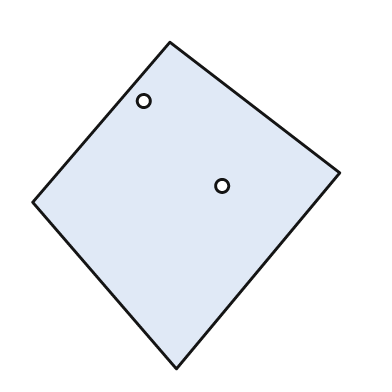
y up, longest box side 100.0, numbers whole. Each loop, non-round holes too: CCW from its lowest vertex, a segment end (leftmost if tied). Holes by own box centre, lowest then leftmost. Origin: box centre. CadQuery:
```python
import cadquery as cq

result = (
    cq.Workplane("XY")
    .moveTo(-3.0, -50.0)
    .lineTo(47.0, 10.0)
    .lineTo(-5.0, 50.0)
    .lineTo(-47.0, 1.0)
    .close()
    .moveTo(11.0, 6.0)
    .circle(2.0)
    .moveTo(-13.0, 32.0)
    .circle(2.0)
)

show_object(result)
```